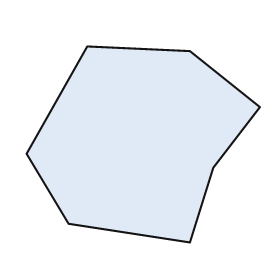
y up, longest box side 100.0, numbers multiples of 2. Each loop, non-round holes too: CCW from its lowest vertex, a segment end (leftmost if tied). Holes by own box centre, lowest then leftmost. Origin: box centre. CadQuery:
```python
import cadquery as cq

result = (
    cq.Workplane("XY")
    .moveTo(20.0, -42.0)
    .lineTo(30.0, -10.0)
    .lineTo(50.0, 16.0)
    .lineTo(20.0, 40.0)
    .lineTo(-24.0, 42.0)
    .lineTo(-50.0, -4.0)
    .lineTo(-32.0, -34.0)
    .close()
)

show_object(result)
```